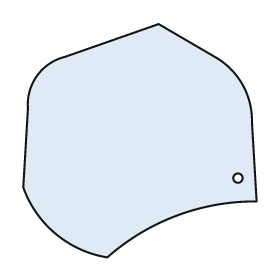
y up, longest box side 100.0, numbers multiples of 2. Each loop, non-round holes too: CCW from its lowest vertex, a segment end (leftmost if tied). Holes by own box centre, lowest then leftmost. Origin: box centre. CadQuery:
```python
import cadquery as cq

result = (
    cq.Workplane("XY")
    .moveTo(-14.0, -50.0)
    .threePointArc((16.0, -32.0), (50.0, -26.0))
    .lineTo(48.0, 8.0)
    .threePointArc((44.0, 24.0), (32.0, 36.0))
    .lineTo(8.0, 50.0)
    .lineTo(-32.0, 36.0)
    .threePointArc((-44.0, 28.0), (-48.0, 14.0))
    .lineTo(-50.0, -20.0)
    .threePointArc((-36.0, -40.0), (-14.0, -50.0))
    .close()
    .moveTo(42.0, -16.0)
    .circle(2.0)
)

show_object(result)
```